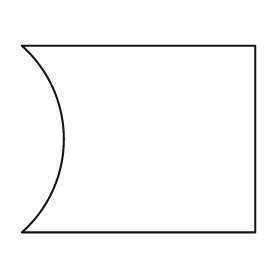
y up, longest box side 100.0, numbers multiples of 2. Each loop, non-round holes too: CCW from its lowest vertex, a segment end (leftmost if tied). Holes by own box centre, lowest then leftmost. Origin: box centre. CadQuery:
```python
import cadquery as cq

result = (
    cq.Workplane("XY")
    .moveTo(-50.0, -40.0)
    .lineTo(50.0, -40.0)
    .lineTo(50.0, 40.0)
    .lineTo(-50.0, 40.0)
    .threePointArc((-32.0, 0.0), (-50.0, -40.0))
    .close()
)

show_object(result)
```